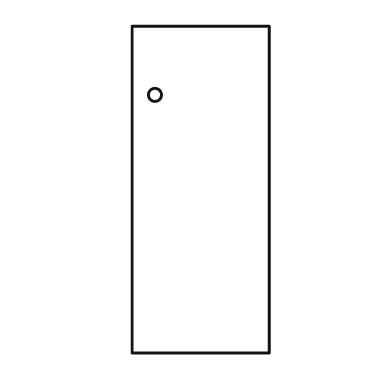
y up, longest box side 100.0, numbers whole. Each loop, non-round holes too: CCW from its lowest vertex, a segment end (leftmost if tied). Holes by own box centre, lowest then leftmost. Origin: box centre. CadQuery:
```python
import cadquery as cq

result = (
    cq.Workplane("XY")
    .moveTo(-21.0, -50.0)
    .lineTo(21.0, -50.0)
    .lineTo(21.0, 50.0)
    .lineTo(-21.0, 50.0)
    .close()
    .moveTo(-14.0, 29.0)
    .circle(2.0)
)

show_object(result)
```